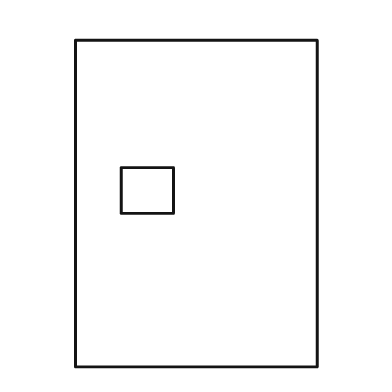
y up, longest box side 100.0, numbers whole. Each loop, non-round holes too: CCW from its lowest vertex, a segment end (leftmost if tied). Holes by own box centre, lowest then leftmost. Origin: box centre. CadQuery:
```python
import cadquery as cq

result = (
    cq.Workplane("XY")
    .moveTo(-37.0, -50.0)
    .lineTo(37.0, -50.0)
    .lineTo(37.0, 50.0)
    .lineTo(-37.0, 50.0)
    .close()
    .moveTo(-23.0, -3.0)
    .lineTo(-7.0, -3.0)
    .lineTo(-7.0, 11.0)
    .lineTo(-23.0, 11.0)
    .close()
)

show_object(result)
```